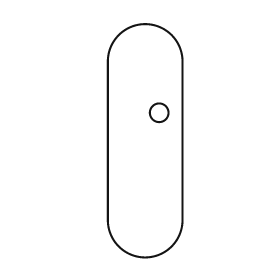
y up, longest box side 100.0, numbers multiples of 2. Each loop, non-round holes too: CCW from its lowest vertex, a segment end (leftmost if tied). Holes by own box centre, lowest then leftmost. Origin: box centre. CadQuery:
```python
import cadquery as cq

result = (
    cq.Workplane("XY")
    .moveTo(-16.0, -34.0)
    .threePointArc((0.0, -50.0), (16.0, -34.0))
    .lineTo(16.0, 34.0)
    .threePointArc((0.0, 50.0), (-16.0, 34.0))
    .close()
    .moveTo(6.0, 12.0)
    .circle(4.0)
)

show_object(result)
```